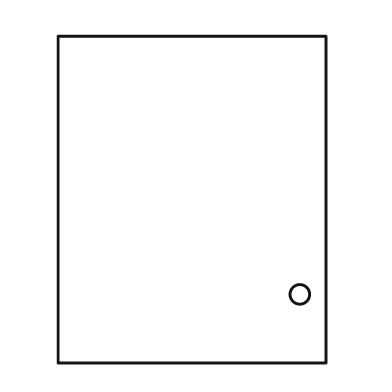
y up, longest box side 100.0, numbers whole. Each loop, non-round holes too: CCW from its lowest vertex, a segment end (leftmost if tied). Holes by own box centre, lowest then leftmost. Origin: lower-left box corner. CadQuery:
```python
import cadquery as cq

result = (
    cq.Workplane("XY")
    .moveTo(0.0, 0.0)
    .lineTo(82.0, 0.0)
    .lineTo(82.0, 100.0)
    .lineTo(0.0, 100.0)
    .close()
    .moveTo(74.0, 21.0)
    .circle(3.0)
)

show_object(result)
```